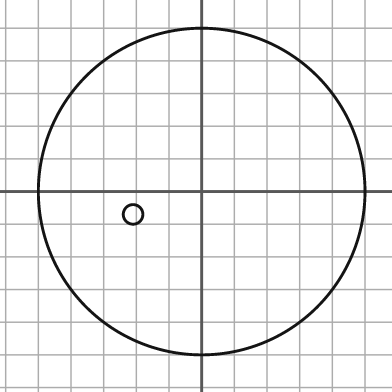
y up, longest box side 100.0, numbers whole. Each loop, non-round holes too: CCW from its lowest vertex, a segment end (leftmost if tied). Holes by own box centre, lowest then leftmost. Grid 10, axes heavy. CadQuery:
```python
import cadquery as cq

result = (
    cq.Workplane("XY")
    .moveTo(0.0, 0.0)
    .circle(50.0)
    .moveTo(-21.0, -7.0)
    .circle(3.0)
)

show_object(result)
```